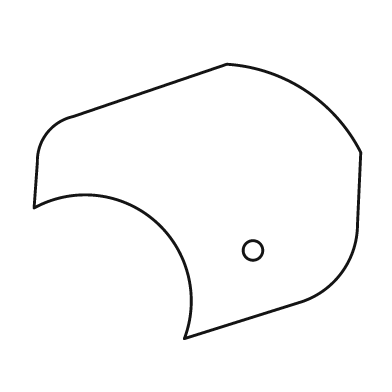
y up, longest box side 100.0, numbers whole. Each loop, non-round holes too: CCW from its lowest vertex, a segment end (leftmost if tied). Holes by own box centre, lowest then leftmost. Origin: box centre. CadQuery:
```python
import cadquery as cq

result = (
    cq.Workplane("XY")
    .moveTo(-4.0, -42.0)
    .lineTo(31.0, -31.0)
    .threePointArc((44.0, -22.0), (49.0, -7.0))
    .lineTo(50.0, 15.0)
    .threePointArc((33.0, 34.0), (9.0, 42.0))
    .lineTo(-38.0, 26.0)
    .threePointArc((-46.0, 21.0), (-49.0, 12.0))
    .lineTo(-50.0, -2.0)
    .threePointArc((-13.0, -6.0), (-4.0, -42.0))
    .close()
    .moveTo(17.0, -15.0)
    .circle(3.0)
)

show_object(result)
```